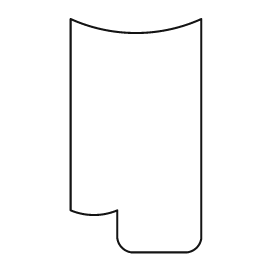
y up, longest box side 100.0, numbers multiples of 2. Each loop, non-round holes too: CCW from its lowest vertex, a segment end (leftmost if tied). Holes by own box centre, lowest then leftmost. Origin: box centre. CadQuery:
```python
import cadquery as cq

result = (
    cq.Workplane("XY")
    .moveTo(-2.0, -50.0)
    .lineTo(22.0, -50.0)
    .threePointArc((26.0, -48.0), (28.0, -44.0))
    .lineTo(28.0, 50.0)
    .threePointArc((0.0, 44.0), (-28.0, 50.0))
    .lineTo(-28.0, -32.0)
    .threePointArc((-18.0, -34.0), (-8.0, -32.0))
    .lineTo(-8.0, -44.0)
    .threePointArc((-6.0, -48.0), (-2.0, -50.0))
    .close()
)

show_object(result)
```